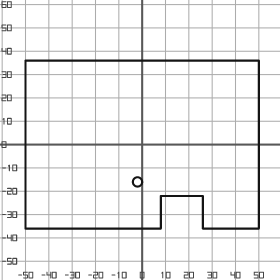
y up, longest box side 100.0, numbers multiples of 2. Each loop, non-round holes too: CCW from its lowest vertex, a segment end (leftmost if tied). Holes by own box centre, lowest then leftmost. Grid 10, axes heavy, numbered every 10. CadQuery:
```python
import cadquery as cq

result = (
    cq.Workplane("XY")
    .moveTo(-50.0, -36.0)
    .lineTo(8.0, -36.0)
    .lineTo(8.0, -22.0)
    .lineTo(26.0, -22.0)
    .lineTo(26.0, -36.0)
    .lineTo(50.0, -36.0)
    .lineTo(50.0, 36.0)
    .lineTo(-50.0, 36.0)
    .close()
    .moveTo(-2.0, -16.0)
    .circle(2.0)
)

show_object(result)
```